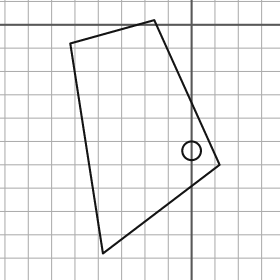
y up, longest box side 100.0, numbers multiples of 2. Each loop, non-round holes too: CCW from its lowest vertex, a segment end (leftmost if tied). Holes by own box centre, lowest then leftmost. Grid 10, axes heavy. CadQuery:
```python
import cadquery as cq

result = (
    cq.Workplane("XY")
    .moveTo(-38.0, -98.0)
    .lineTo(12.0, -60.0)
    .lineTo(-16.0, 2.0)
    .lineTo(-52.0, -8.0)
    .close()
    .moveTo(0.0, -54.0)
    .circle(4.0)
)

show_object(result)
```